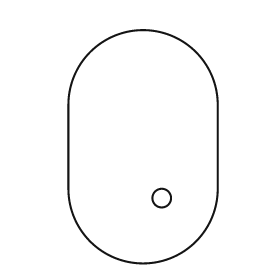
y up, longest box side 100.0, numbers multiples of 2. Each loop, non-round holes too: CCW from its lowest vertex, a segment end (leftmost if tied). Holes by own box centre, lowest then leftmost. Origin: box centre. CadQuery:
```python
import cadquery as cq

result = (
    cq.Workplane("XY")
    .moveTo(-32.0, -18.0)
    .threePointArc((0.0, -50.0), (32.0, -18.0))
    .lineTo(32.0, 18.0)
    .threePointArc((0.0, 50.0), (-32.0, 18.0))
    .close()
    .moveTo(8.0, -22.0)
    .circle(4.0)
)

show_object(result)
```